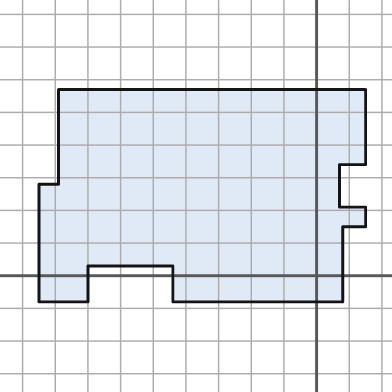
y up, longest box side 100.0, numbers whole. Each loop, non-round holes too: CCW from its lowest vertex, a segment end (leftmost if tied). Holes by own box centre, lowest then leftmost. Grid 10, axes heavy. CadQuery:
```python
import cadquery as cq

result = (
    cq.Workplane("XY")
    .moveTo(-85.0, -8.0)
    .lineTo(-70.0, -8.0)
    .lineTo(-70.0, 3.0)
    .lineTo(-44.0, 3.0)
    .lineTo(-44.0, -8.0)
    .lineTo(8.0, -8.0)
    .lineTo(8.0, 15.0)
    .lineTo(15.0, 15.0)
    .lineTo(15.0, 21.0)
    .lineTo(7.0, 21.0)
    .lineTo(7.0, 34.0)
    .lineTo(15.0, 34.0)
    .lineTo(15.0, 57.0)
    .lineTo(-79.0, 57.0)
    .lineTo(-79.0, 28.0)
    .lineTo(-85.0, 28.0)
    .close()
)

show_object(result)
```